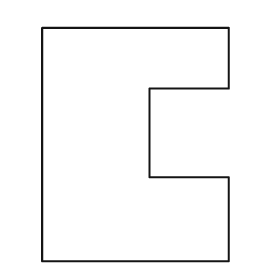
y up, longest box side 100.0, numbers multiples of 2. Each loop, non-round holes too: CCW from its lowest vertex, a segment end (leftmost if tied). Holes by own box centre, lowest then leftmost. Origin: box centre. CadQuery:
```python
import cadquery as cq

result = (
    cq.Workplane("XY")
    .moveTo(-40.0, -50.0)
    .lineTo(40.0, -50.0)
    .lineTo(40.0, -14.0)
    .lineTo(6.0, -14.0)
    .lineTo(6.0, 24.0)
    .lineTo(40.0, 24.0)
    .lineTo(40.0, 50.0)
    .lineTo(-40.0, 50.0)
    .close()
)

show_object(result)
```